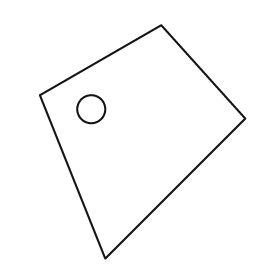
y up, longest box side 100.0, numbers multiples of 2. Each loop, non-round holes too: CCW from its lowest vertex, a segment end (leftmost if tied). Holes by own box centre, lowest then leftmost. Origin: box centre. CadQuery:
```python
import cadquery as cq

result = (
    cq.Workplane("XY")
    .moveTo(-16.0, -50.0)
    .lineTo(44.0, 10.0)
    .lineTo(8.0, 50.0)
    .lineTo(-44.0, 20.0)
    .close()
    .moveTo(-22.0, 14.0)
    .circle(6.0)
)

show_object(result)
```